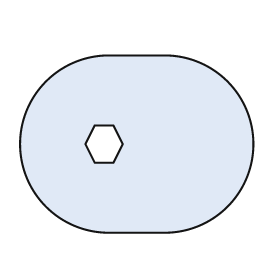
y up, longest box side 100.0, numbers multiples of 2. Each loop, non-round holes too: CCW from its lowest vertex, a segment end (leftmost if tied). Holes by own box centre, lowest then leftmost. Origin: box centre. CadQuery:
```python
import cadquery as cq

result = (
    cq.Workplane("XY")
    .moveTo(-12.0, -38.0)
    .lineTo(12.0, -38.0)
    .threePointArc((50.0, 0.0), (12.0, 38.0))
    .lineTo(-12.0, 38.0)
    .threePointArc((-50.0, 0.0), (-12.0, -38.0))
    .close()
    .moveTo(-18.0, -8.0)
    .lineTo(-10.0, -8.0)
    .lineTo(-6.0, 0.0)
    .lineTo(-10.0, 8.0)
    .lineTo(-18.0, 8.0)
    .lineTo(-22.0, 0.0)
    .close()
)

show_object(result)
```